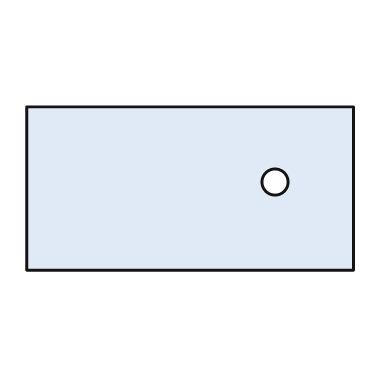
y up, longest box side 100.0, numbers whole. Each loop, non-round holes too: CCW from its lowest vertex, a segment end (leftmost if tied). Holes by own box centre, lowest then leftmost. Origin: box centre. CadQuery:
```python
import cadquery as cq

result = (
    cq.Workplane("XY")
    .moveTo(-50.0, -25.0)
    .lineTo(50.0, -25.0)
    .lineTo(50.0, 25.0)
    .lineTo(-50.0, 25.0)
    .close()
    .moveTo(26.0, 2.0)
    .circle(4.0)
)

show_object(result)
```